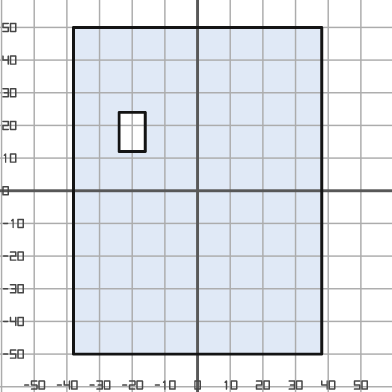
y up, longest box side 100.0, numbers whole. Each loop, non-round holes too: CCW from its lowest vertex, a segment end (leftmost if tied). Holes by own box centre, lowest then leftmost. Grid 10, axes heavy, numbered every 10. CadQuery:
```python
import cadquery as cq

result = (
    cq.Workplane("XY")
    .moveTo(-38.0, -50.0)
    .lineTo(38.0, -50.0)
    .lineTo(38.0, 50.0)
    .lineTo(-38.0, 50.0)
    .close()
    .moveTo(-24.0, 12.0)
    .lineTo(-16.0, 12.0)
    .lineTo(-16.0, 24.0)
    .lineTo(-24.0, 24.0)
    .close()
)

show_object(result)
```